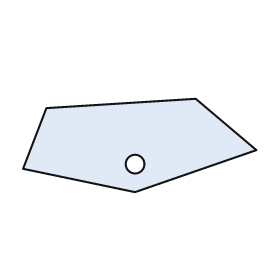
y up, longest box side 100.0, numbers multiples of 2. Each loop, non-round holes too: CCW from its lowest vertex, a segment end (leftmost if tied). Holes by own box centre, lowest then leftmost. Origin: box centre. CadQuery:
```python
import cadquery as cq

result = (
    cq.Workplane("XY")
    .moveTo(-2.0, -20.0)
    .lineTo(50.0, -2.0)
    .lineTo(24.0, 20.0)
    .lineTo(-40.0, 16.0)
    .lineTo(-50.0, -10.0)
    .close()
    .moveTo(-2.0, -8.0)
    .circle(4.0)
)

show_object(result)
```